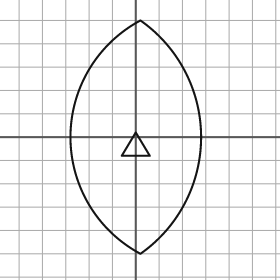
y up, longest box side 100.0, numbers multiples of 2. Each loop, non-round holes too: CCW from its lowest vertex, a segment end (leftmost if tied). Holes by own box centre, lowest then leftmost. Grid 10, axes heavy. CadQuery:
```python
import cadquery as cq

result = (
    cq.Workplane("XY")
    .moveTo(2.0, -50.0)
    .threePointArc((28.0, 0.0), (2.0, 50.0))
    .threePointArc((-28.0, 0.0), (2.0, -50.0))
    .close()
    .moveTo(-6.0, -8.0)
    .lineTo(6.0, -8.0)
    .lineTo(0.0, 2.0)
    .close()
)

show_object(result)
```